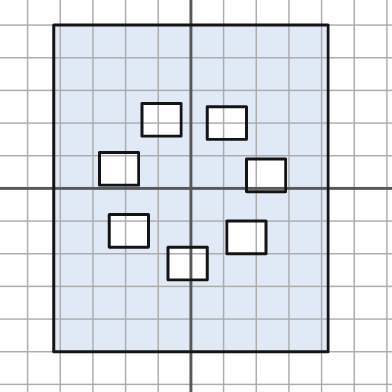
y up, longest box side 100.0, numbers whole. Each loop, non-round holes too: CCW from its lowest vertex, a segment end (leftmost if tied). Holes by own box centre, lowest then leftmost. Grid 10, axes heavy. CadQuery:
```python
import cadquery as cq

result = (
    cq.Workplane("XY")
    .moveTo(-42.0, -50.0)
    .lineTo(42.0, -50.0)
    .lineTo(42.0, 50.0)
    .lineTo(-42.0, 50.0)
    .close()
    .moveTo(-7.0, -28.0)
    .lineTo(5.0, -28.0)
    .lineTo(5.0, -18.0)
    .lineTo(-7.0, -18.0)
    .close()
    .moveTo(11.0, -20.0)
    .lineTo(23.0, -20.0)
    .lineTo(23.0, -10.0)
    .lineTo(11.0, -10.0)
    .close()
    .moveTo(-25.0, -18.0)
    .lineTo(-13.0, -18.0)
    .lineTo(-13.0, -8.0)
    .lineTo(-25.0, -8.0)
    .close()
    .moveTo(17.0, -1.0)
    .lineTo(29.0, -1.0)
    .lineTo(29.0, 9.0)
    .lineTo(17.0, 9.0)
    .close()
    .moveTo(-28.0, 1.0)
    .lineTo(-16.0, 1.0)
    .lineTo(-16.0, 11.0)
    .lineTo(-28.0, 11.0)
    .close()
    .moveTo(5.0, 15.0)
    .lineTo(17.0, 15.0)
    .lineTo(17.0, 25.0)
    .lineTo(5.0, 25.0)
    .close()
    .moveTo(-15.0, 16.0)
    .lineTo(-3.0, 16.0)
    .lineTo(-3.0, 26.0)
    .lineTo(-15.0, 26.0)
    .close()
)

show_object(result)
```